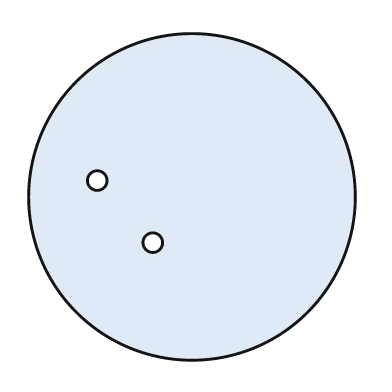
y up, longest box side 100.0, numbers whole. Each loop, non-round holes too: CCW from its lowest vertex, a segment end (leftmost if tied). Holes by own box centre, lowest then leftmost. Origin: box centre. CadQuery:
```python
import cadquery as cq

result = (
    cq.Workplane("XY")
    .moveTo(0.0, 0.0)
    .circle(50.0)
    .moveTo(-12.0, -14.0)
    .circle(3.0)
    .moveTo(-29.0, 5.0)
    .circle(3.0)
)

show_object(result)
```